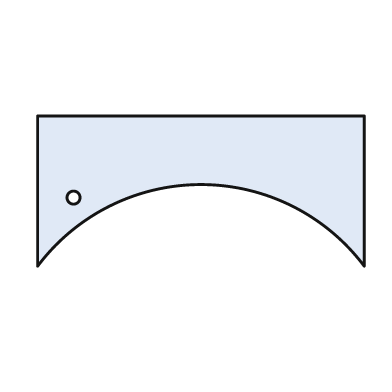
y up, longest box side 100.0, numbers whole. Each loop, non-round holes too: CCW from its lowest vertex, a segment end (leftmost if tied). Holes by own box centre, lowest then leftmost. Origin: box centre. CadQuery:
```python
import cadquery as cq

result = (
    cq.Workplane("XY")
    .moveTo(-50.0, -23.0)
    .threePointArc((0.0, 2.0), (50.0, -23.0))
    .lineTo(50.0, 23.0)
    .lineTo(-50.0, 23.0)
    .close()
    .moveTo(-39.0, -2.0)
    .circle(2.0)
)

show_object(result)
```